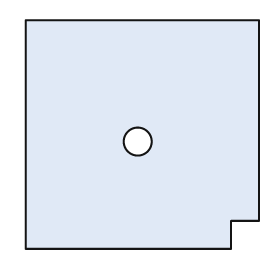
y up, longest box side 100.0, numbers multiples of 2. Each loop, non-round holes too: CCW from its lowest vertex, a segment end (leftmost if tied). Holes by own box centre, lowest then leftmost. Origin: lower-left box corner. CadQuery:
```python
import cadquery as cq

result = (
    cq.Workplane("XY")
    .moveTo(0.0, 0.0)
    .lineTo(88.0, 0.0)
    .lineTo(88.0, 12.0)
    .lineTo(100.0, 12.0)
    .lineTo(100.0, 98.0)
    .lineTo(0.0, 98.0)
    .close()
    .moveTo(48.0, 46.0)
    .circle(6.0)
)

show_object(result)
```